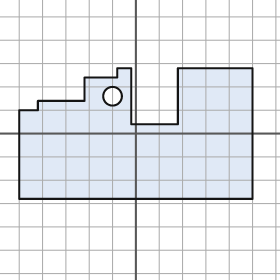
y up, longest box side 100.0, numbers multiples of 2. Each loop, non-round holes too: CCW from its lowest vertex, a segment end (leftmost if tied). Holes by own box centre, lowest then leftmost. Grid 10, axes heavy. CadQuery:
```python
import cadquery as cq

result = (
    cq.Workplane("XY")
    .moveTo(-50.0, -28.0)
    .lineTo(50.0, -28.0)
    .lineTo(50.0, 28.0)
    .lineTo(18.0, 28.0)
    .lineTo(18.0, 4.0)
    .lineTo(-2.0, 4.0)
    .lineTo(-2.0, 28.0)
    .lineTo(-8.0, 28.0)
    .lineTo(-8.0, 24.0)
    .lineTo(-22.0, 24.0)
    .lineTo(-22.0, 14.0)
    .lineTo(-42.0, 14.0)
    .lineTo(-42.0, 10.0)
    .lineTo(-50.0, 10.0)
    .close()
    .moveTo(-10.0, 16.0)
    .circle(4.0)
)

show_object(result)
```